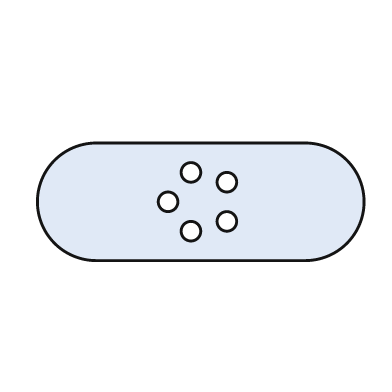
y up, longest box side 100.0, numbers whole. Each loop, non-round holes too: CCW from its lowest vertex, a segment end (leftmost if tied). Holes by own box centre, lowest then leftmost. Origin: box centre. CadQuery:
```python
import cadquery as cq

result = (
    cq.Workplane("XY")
    .moveTo(-32.0, -18.0)
    .lineTo(32.0, -18.0)
    .threePointArc((50.0, 0.0), (32.0, 18.0))
    .lineTo(-32.0, 18.0)
    .threePointArc((-50.0, 0.0), (-32.0, -18.0))
    .close()
    .moveTo(-3.0, -9.0)
    .circle(3.0)
    .moveTo(8.0, -6.0)
    .circle(3.0)
    .moveTo(-10.0, 0.0)
    .circle(3.0)
    .moveTo(8.0, 6.0)
    .circle(3.0)
    .moveTo(-3.0, 9.0)
    .circle(3.0)
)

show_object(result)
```